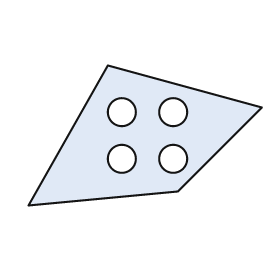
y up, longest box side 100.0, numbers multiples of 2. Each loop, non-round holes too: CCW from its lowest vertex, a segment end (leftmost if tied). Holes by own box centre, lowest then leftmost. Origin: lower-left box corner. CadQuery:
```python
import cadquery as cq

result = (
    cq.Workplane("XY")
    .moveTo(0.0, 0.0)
    .lineTo(64.0, 6.0)
    .lineTo(100.0, 42.0)
    .lineTo(34.0, 60.0)
    .close()
    .moveTo(40.0, 20.0)
    .circle(6.0)
    .moveTo(62.0, 20.0)
    .circle(6.0)
    .moveTo(40.0, 40.0)
    .circle(6.0)
    .moveTo(62.0, 40.0)
    .circle(6.0)
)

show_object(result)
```